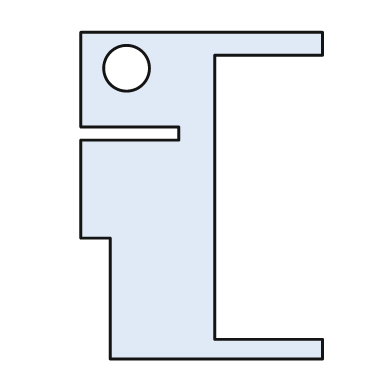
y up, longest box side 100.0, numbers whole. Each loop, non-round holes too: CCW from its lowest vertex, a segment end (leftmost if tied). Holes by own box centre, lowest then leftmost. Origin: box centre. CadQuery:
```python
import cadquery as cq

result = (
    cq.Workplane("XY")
    .moveTo(-28.0, -50.0)
    .lineTo(37.0, -50.0)
    .lineTo(37.0, -44.0)
    .lineTo(4.0, -44.0)
    .lineTo(4.0, 43.0)
    .lineTo(37.0, 43.0)
    .lineTo(37.0, 50.0)
    .lineTo(-37.0, 50.0)
    .lineTo(-37.0, 21.0)
    .lineTo(-7.0, 21.0)
    .lineTo(-7.0, 17.0)
    .lineTo(-37.0, 17.0)
    .lineTo(-37.0, -13.0)
    .lineTo(-28.0, -13.0)
    .close()
    .moveTo(-23.0, 39.0)
    .circle(7.0)
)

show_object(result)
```